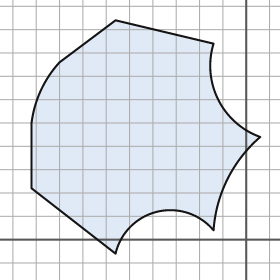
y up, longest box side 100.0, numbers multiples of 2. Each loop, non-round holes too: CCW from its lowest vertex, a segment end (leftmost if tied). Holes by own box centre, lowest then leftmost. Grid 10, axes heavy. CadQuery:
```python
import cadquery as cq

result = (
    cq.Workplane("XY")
    .moveTo(-56.0, -6.0)
    .threePointArc((-38.0, 12.0), (-14.0, 4.0))
    .threePointArc((-8.0, 26.0), (6.0, 44.0))
    .threePointArc((-12.0, 60.0), (-14.0, 84.0))
    .lineTo(-56.0, 94.0)
    .lineTo(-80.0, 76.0)
    .threePointArc((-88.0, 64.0), (-92.0, 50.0))
    .lineTo(-92.0, 22.0)
    .close()
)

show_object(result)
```